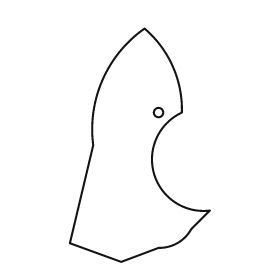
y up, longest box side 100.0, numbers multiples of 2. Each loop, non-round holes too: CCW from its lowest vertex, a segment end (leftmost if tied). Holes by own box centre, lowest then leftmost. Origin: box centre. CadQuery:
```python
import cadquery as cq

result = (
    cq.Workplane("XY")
    .moveTo(-8.0, -50.0)
    .lineTo(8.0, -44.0)
    .threePointArc((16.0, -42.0), (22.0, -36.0))
    .lineTo(30.0, -28.0)
    .threePointArc((6.0, -12.0), (18.0, 14.0))
    .threePointArc((14.0, 34.0), (2.0, 50.0))
    .threePointArc((-16.0, 28.0), (-20.0, 0.0))
    .lineTo(-30.0, -42.0)
    .close()
    .moveTo(8.0, 14.0)
    .circle(2.0)
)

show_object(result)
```